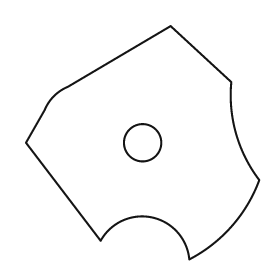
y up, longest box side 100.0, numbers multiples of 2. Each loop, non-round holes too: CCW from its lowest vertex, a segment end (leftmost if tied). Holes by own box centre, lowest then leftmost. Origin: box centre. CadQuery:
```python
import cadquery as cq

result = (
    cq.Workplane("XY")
    .moveTo(20.0, -50.0)
    .threePointArc((38.0, -36.0), (50.0, -16.0))
    .threePointArc((40.0, 4.0), (38.0, 26.0))
    .lineTo(12.0, 50.0)
    .lineTo(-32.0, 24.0)
    .threePointArc((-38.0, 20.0), (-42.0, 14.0))
    .lineTo(-50.0, 0.0)
    .lineTo(-18.0, -42.0)
    .threePointArc((4.0, -32.0), (20.0, -50.0))
    .close()
    .moveTo(0.0, 0.0)
    .circle(8.0)
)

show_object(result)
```